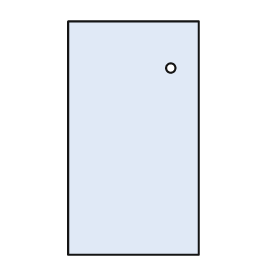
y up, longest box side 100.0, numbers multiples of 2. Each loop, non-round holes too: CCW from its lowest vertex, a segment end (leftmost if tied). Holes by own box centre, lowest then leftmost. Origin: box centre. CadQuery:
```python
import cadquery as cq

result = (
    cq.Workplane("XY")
    .moveTo(-28.0, -50.0)
    .lineTo(28.0, -50.0)
    .lineTo(28.0, 50.0)
    .lineTo(-28.0, 50.0)
    .close()
    .moveTo(16.0, 30.0)
    .circle(2.0)
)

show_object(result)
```